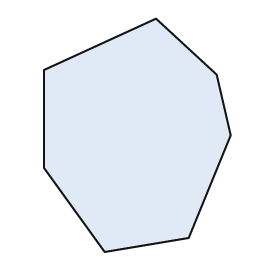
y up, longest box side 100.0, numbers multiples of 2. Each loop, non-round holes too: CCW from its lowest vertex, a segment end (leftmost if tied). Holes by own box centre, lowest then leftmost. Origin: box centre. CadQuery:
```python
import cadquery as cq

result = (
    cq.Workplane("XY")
    .moveTo(-14.0, -50.0)
    .lineTo(22.0, -44.0)
    .lineTo(40.0, 0.0)
    .lineTo(34.0, 26.0)
    .lineTo(8.0, 50.0)
    .lineTo(-40.0, 28.0)
    .lineTo(-40.0, -14.0)
    .close()
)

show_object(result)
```